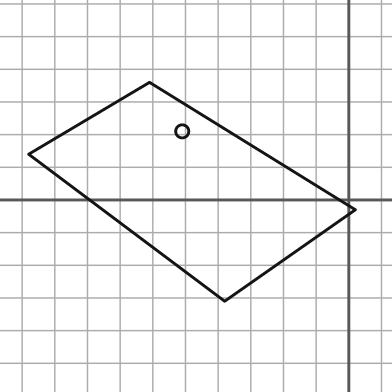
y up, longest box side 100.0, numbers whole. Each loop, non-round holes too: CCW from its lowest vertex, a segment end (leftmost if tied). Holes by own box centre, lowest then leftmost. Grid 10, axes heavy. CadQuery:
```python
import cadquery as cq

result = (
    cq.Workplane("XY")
    .moveTo(-38.0, -31.0)
    .lineTo(2.0, -3.0)
    .lineTo(-61.0, 36.0)
    .lineTo(-98.0, 14.0)
    .close()
    .moveTo(-51.0, 21.0)
    .circle(2.0)
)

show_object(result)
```